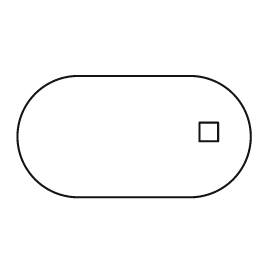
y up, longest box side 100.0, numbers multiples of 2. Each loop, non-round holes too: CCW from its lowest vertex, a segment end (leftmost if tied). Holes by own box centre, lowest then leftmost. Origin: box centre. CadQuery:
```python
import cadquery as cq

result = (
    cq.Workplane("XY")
    .moveTo(-24.0, -26.0)
    .lineTo(24.0, -26.0)
    .threePointArc((50.0, 0.0), (24.0, 26.0))
    .lineTo(-24.0, 26.0)
    .threePointArc((-50.0, 0.0), (-24.0, -26.0))
    .close()
    .moveTo(28.0, -2.0)
    .lineTo(36.0, -2.0)
    .lineTo(36.0, 6.0)
    .lineTo(28.0, 6.0)
    .close()
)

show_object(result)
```